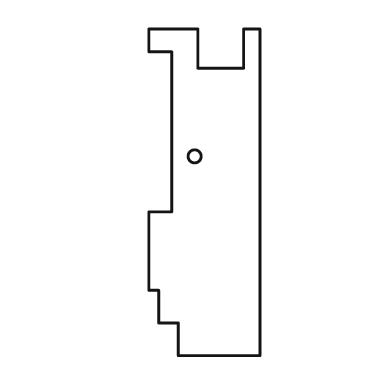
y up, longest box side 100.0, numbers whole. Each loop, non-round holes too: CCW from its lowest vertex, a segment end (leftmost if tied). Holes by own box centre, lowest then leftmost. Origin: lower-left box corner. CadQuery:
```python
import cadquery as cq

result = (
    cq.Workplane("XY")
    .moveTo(9.0, 0.0)
    .lineTo(34.0, 0.0)
    .lineTo(34.0, 100.0)
    .lineTo(29.0, 100.0)
    .lineTo(29.0, 88.0)
    .lineTo(15.0, 88.0)
    .lineTo(15.0, 100.0)
    .lineTo(0.0, 100.0)
    .lineTo(0.0, 93.0)
    .lineTo(7.0, 93.0)
    .lineTo(7.0, 44.0)
    .lineTo(0.0, 44.0)
    .lineTo(0.0, 20.0)
    .lineTo(3.0, 20.0)
    .lineTo(3.0, 10.0)
    .lineTo(9.0, 10.0)
    .close()
    .moveTo(14.0, 61.0)
    .circle(2.0)
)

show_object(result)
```